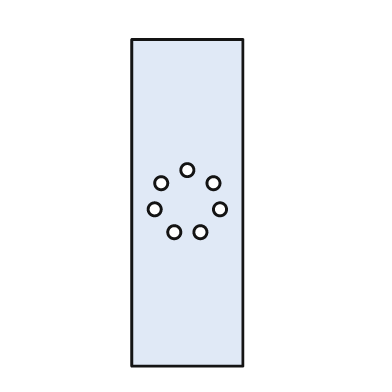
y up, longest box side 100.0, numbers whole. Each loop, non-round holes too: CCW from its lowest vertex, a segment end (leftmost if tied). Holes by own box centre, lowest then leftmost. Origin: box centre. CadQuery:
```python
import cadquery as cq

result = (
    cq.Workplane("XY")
    .moveTo(-17.0, -50.0)
    .lineTo(17.0, -50.0)
    .lineTo(17.0, 50.0)
    .lineTo(-17.0, 50.0)
    .close()
    .moveTo(-4.0, -9.0)
    .circle(2.0)
    .moveTo(4.0, -9.0)
    .circle(2.0)
    .moveTo(-10.0, -2.0)
    .circle(2.0)
    .moveTo(10.0, -2.0)
    .circle(2.0)
    .moveTo(-8.0, 6.0)
    .circle(2.0)
    .moveTo(8.0, 6.0)
    .circle(2.0)
    .moveTo(0.0, 10.0)
    .circle(2.0)
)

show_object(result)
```